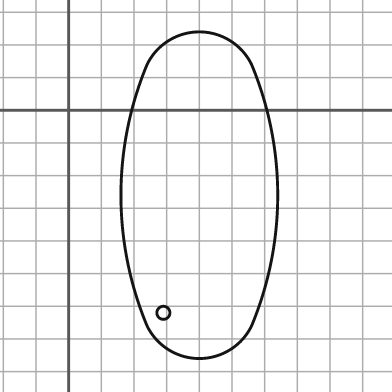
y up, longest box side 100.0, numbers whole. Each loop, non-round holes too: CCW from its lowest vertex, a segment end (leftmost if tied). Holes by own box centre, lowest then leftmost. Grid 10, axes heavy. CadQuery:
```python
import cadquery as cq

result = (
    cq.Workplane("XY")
    .moveTo(24.0, -66.0)
    .threePointArc((40.0, -76.0), (56.0, -66.0))
    .threePointArc((64.0, -26.0), (56.0, 14.0))
    .threePointArc((40.0, 24.0), (24.0, 14.0))
    .threePointArc((16.0, -26.0), (24.0, -66.0))
    .close()
    .moveTo(29.0, -62.0)
    .circle(2.0)
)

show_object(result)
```